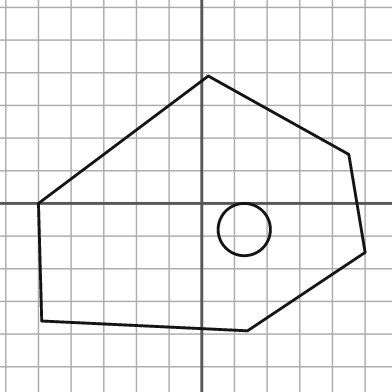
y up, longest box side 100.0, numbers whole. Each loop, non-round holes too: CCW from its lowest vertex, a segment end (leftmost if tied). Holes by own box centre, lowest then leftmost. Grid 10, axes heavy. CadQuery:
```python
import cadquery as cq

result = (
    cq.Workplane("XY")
    .moveTo(14.0, -39.0)
    .lineTo(50.0, -15.0)
    .lineTo(45.0, 15.0)
    .lineTo(2.0, 39.0)
    .lineTo(-50.0, 0.0)
    .lineTo(-49.0, -36.0)
    .close()
    .moveTo(13.0, -8.0)
    .circle(8.0)
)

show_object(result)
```